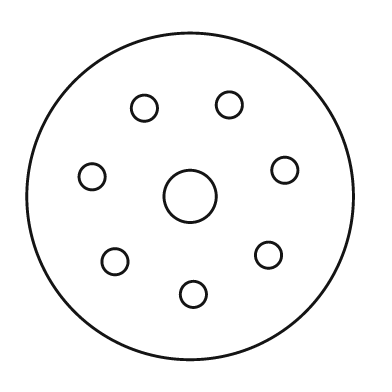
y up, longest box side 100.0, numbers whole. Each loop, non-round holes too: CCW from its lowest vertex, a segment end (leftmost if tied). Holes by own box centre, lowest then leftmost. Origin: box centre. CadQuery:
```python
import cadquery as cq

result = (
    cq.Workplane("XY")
    .moveTo(0.0, 0.0)
    .circle(50.0)
    .moveTo(1.0, -30.0)
    .circle(4.0)
    .moveTo(-23.0, -20.0)
    .circle(4.0)
    .moveTo(24.0, -18.0)
    .circle(4.0)
    .moveTo(0.0, 0.0)
    .circle(8.0)
    .moveTo(-30.0, 6.0)
    .circle(4.0)
    .moveTo(29.0, 8.0)
    .circle(4.0)
    .moveTo(-14.0, 27.0)
    .circle(4.0)
    .moveTo(12.0, 28.0)
    .circle(4.0)
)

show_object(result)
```